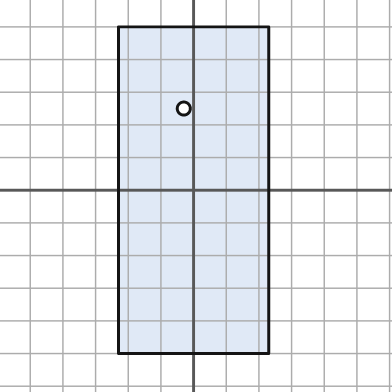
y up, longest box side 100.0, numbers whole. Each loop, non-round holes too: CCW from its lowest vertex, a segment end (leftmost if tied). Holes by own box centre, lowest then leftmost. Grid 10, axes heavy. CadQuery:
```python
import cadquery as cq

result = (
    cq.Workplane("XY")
    .moveTo(-23.0, -50.0)
    .lineTo(23.0, -50.0)
    .lineTo(23.0, 50.0)
    .lineTo(-23.0, 50.0)
    .close()
    .moveTo(-3.0, 25.0)
    .circle(2.0)
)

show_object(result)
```